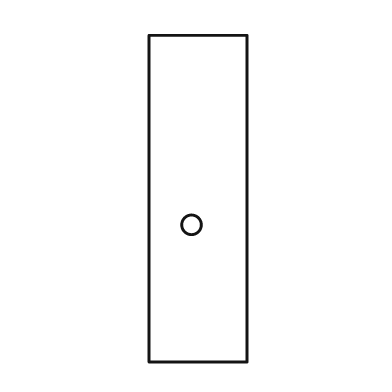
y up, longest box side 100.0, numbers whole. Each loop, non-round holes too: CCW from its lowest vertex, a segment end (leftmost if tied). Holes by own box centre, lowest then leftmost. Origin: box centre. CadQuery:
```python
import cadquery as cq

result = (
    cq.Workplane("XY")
    .moveTo(-15.0, -50.0)
    .lineTo(15.0, -50.0)
    .lineTo(15.0, 50.0)
    .lineTo(-15.0, 50.0)
    .close()
    .moveTo(-2.0, -8.0)
    .circle(3.0)
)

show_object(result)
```